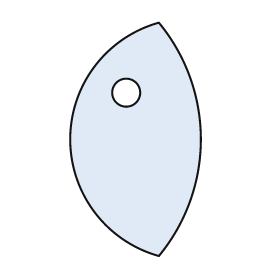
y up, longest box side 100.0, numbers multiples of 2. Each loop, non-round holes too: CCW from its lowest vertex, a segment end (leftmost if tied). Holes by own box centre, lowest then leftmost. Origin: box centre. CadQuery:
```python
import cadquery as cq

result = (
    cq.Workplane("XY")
    .moveTo(10.0, -50.0)
    .threePointArc((28.0, 0.0), (10.0, 50.0))
    .threePointArc((-28.0, 0.0), (10.0, -50.0))
    .close()
    .moveTo(-4.0, 20.0)
    .circle(6.0)
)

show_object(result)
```